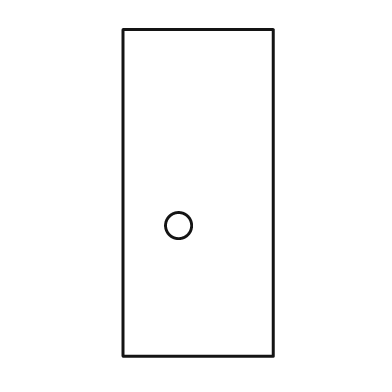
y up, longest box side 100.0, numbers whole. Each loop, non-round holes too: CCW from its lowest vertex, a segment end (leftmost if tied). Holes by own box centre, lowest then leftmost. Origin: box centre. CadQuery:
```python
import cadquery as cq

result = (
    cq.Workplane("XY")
    .moveTo(-23.0, -50.0)
    .lineTo(23.0, -50.0)
    .lineTo(23.0, 50.0)
    .lineTo(-23.0, 50.0)
    .close()
    .moveTo(-6.0, -10.0)
    .circle(4.0)
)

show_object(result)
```